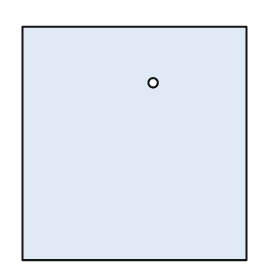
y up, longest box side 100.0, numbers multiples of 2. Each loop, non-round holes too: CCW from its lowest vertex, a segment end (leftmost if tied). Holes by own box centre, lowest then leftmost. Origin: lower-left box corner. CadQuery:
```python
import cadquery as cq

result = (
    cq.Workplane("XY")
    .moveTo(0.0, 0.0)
    .lineTo(96.0, 0.0)
    .lineTo(96.0, 100.0)
    .lineTo(0.0, 100.0)
    .close()
    .moveTo(56.0, 76.0)
    .circle(2.0)
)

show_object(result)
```